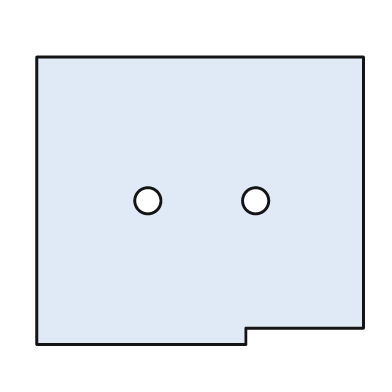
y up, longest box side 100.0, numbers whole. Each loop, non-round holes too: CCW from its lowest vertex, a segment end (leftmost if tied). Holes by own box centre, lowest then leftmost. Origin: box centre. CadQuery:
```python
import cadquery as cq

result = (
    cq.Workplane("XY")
    .moveTo(-50.0, -44.0)
    .lineTo(14.0, -44.0)
    .lineTo(14.0, -39.0)
    .lineTo(50.0, -39.0)
    .lineTo(50.0, 44.0)
    .lineTo(-50.0, 44.0)
    .close()
    .moveTo(-16.0, 0.0)
    .circle(4.0)
    .moveTo(17.0, 0.0)
    .circle(4.0)
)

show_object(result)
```